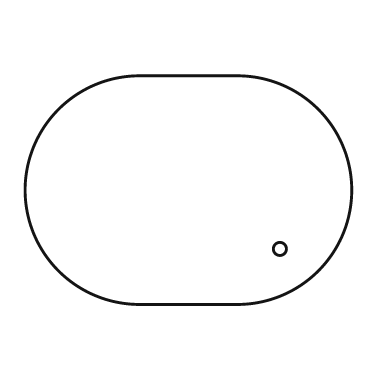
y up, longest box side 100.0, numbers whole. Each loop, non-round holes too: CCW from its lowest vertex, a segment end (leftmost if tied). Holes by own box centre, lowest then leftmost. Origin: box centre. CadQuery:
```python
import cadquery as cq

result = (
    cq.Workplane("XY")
    .moveTo(-15.0, -35.0)
    .lineTo(15.0, -35.0)
    .threePointArc((50.0, 0.0), (15.0, 35.0))
    .lineTo(-15.0, 35.0)
    .threePointArc((-50.0, 0.0), (-15.0, -35.0))
    .close()
    .moveTo(28.0, -18.0)
    .circle(2.0)
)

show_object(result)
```